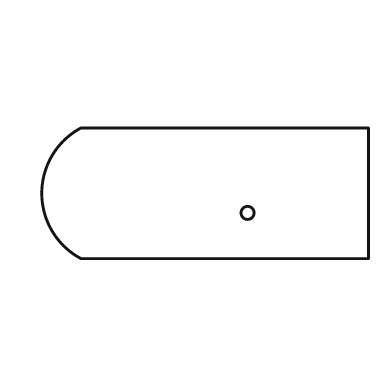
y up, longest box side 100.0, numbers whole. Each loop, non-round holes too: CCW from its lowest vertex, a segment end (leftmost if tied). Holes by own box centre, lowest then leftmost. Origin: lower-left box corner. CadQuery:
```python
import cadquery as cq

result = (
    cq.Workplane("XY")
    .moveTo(12.0, 0.0)
    .lineTo(100.0, 0.0)
    .lineTo(100.0, 40.0)
    .lineTo(12.0, 40.0)
    .threePointArc((0.0, 20.0), (12.0, 0.0))
    .close()
    .moveTo(63.0, 14.0)
    .circle(2.0)
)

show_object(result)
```